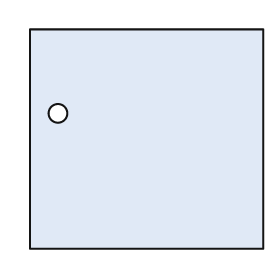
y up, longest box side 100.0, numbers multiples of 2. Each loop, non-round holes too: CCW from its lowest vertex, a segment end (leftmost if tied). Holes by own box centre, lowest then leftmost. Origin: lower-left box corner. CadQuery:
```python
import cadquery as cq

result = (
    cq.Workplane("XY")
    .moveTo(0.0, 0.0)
    .lineTo(100.0, 0.0)
    .lineTo(100.0, 94.0)
    .lineTo(0.0, 94.0)
    .close()
    .moveTo(12.0, 58.0)
    .circle(4.0)
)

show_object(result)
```